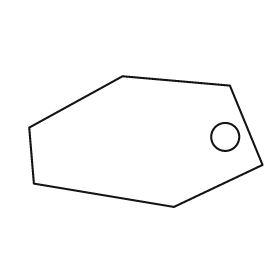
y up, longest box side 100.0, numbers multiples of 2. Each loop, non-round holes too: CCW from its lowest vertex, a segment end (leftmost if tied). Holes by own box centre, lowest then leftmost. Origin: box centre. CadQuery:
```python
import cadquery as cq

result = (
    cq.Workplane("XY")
    .moveTo(12.0, -28.0)
    .lineTo(50.0, -10.0)
    .lineTo(36.0, 24.0)
    .lineTo(-10.0, 28.0)
    .lineTo(-50.0, 6.0)
    .lineTo(-48.0, -18.0)
    .close()
    .moveTo(34.0, 2.0)
    .circle(6.0)
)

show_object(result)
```